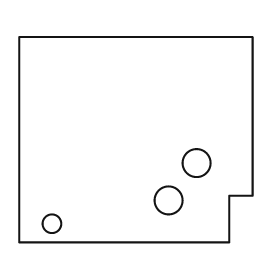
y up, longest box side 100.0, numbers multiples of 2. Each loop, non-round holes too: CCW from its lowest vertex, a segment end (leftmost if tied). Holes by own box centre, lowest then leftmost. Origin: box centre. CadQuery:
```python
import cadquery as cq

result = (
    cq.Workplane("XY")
    .moveTo(-50.0, -44.0)
    .lineTo(40.0, -44.0)
    .lineTo(40.0, -24.0)
    .lineTo(50.0, -24.0)
    .lineTo(50.0, 44.0)
    .lineTo(-50.0, 44.0)
    .close()
    .moveTo(-36.0, -36.0)
    .circle(4.0)
    .moveTo(14.0, -26.0)
    .circle(6.0)
    .moveTo(26.0, -10.0)
    .circle(6.0)
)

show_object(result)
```